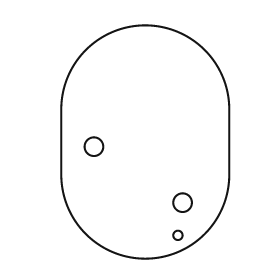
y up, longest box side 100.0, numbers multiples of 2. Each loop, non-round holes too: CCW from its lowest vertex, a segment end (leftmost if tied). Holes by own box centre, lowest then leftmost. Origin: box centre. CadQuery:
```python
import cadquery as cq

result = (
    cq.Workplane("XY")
    .moveTo(-36.0, -14.0)
    .threePointArc((0.0, -50.0), (36.0, -14.0))
    .lineTo(36.0, 14.0)
    .threePointArc((0.0, 50.0), (-36.0, 14.0))
    .close()
    .moveTo(14.0, -40.0)
    .circle(2.0)
    .moveTo(16.0, -26.0)
    .circle(4.0)
    .moveTo(-22.0, -2.0)
    .circle(4.0)
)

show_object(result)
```